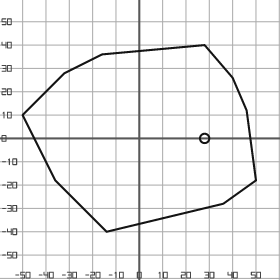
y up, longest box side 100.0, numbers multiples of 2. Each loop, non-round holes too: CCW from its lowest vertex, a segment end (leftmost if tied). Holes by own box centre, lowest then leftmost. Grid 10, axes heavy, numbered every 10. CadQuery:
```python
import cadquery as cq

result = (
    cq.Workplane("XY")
    .moveTo(-14.0, -40.0)
    .lineTo(36.0, -28.0)
    .lineTo(50.0, -18.0)
    .lineTo(46.0, 12.0)
    .lineTo(40.0, 26.0)
    .lineTo(28.0, 40.0)
    .lineTo(-16.0, 36.0)
    .lineTo(-32.0, 28.0)
    .lineTo(-50.0, 10.0)
    .lineTo(-36.0, -18.0)
    .close()
    .moveTo(28.0, 0.0)
    .circle(2.0)
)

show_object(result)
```